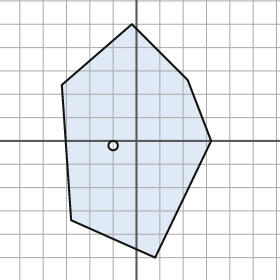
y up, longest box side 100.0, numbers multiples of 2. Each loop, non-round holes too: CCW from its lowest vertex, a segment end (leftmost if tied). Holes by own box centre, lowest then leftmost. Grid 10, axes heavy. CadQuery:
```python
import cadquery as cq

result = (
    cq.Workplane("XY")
    .moveTo(8.0, -50.0)
    .lineTo(32.0, 0.0)
    .lineTo(22.0, 26.0)
    .lineTo(-2.0, 50.0)
    .lineTo(-32.0, 24.0)
    .lineTo(-28.0, -34.0)
    .close()
    .moveTo(-10.0, -2.0)
    .circle(2.0)
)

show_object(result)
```